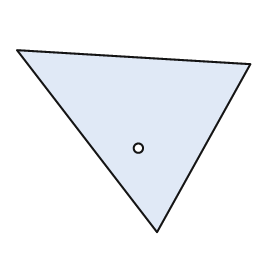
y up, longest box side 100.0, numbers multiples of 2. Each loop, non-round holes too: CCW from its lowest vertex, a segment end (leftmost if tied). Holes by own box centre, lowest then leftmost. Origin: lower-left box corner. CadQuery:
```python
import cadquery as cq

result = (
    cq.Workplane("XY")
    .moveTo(60.0, 0.0)
    .lineTo(100.0, 72.0)
    .lineTo(0.0, 78.0)
    .close()
    .moveTo(52.0, 36.0)
    .circle(2.0)
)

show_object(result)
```